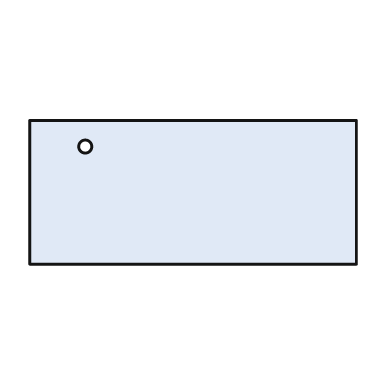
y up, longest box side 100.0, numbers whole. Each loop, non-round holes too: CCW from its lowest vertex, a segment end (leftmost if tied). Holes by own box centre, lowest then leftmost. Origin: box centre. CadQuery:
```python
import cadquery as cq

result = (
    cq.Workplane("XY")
    .moveTo(-50.0, -22.0)
    .lineTo(50.0, -22.0)
    .lineTo(50.0, 22.0)
    .lineTo(-50.0, 22.0)
    .close()
    .moveTo(-33.0, 14.0)
    .circle(2.0)
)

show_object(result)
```